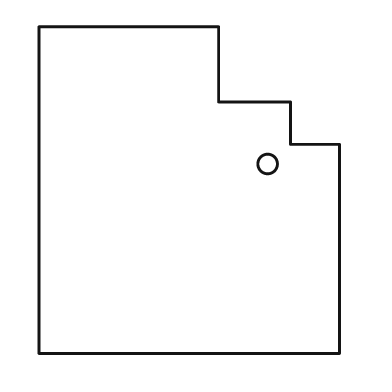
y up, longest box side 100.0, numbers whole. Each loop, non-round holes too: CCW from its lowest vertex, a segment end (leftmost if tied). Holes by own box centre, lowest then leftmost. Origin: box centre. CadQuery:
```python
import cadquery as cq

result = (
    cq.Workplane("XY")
    .moveTo(-46.0, -50.0)
    .lineTo(46.0, -50.0)
    .lineTo(46.0, 14.0)
    .lineTo(31.0, 14.0)
    .lineTo(31.0, 27.0)
    .lineTo(9.0, 27.0)
    .lineTo(9.0, 50.0)
    .lineTo(-46.0, 50.0)
    .close()
    .moveTo(24.0, 8.0)
    .circle(3.0)
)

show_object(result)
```